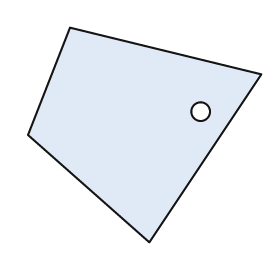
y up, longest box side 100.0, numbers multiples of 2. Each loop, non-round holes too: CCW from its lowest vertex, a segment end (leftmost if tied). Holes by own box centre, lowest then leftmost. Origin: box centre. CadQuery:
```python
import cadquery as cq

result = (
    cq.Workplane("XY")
    .moveTo(2.0, -46.0)
    .lineTo(50.0, 26.0)
    .lineTo(-32.0, 46.0)
    .lineTo(-50.0, 0.0)
    .close()
    .moveTo(24.0, 10.0)
    .circle(4.0)
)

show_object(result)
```